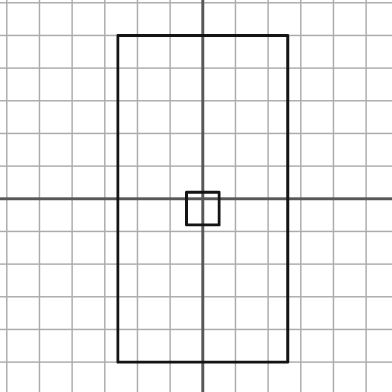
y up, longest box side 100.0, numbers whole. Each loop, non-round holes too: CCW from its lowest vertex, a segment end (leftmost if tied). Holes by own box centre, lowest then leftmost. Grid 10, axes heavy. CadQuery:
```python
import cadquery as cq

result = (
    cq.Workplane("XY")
    .moveTo(-26.0, -50.0)
    .lineTo(26.0, -50.0)
    .lineTo(26.0, 50.0)
    .lineTo(-26.0, 50.0)
    .close()
    .moveTo(-5.0, -8.0)
    .lineTo(5.0, -8.0)
    .lineTo(5.0, 2.0)
    .lineTo(-5.0, 2.0)
    .close()
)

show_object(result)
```